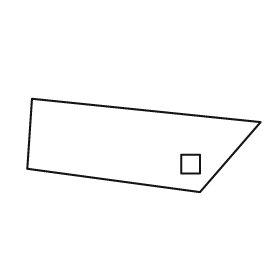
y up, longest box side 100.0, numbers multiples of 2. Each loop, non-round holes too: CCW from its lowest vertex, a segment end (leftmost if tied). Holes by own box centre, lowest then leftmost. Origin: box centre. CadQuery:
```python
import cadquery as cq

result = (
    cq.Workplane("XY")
    .moveTo(24.0, -20.0)
    .lineTo(50.0, 10.0)
    .lineTo(-48.0, 20.0)
    .lineTo(-50.0, -10.0)
    .close()
    .moveTo(16.0, -12.0)
    .lineTo(24.0, -12.0)
    .lineTo(24.0, -4.0)
    .lineTo(16.0, -4.0)
    .close()
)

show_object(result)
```